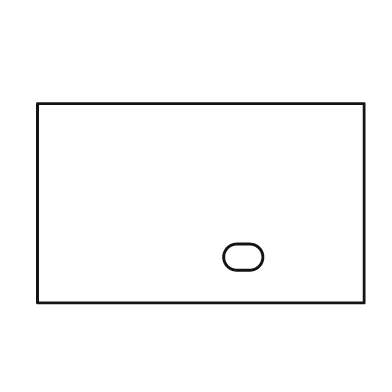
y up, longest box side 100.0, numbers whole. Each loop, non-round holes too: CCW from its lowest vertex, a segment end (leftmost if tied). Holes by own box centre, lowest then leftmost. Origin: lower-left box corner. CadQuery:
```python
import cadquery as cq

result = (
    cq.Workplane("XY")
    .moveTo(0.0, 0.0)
    .lineTo(100.0, 0.0)
    .lineTo(100.0, 61.0)
    .lineTo(0.0, 61.0)
    .close()
    .moveTo(61.0, 10.0)
    .lineTo(65.0, 10.0)
    .threePointArc((69.0, 14.0), (65.0, 18.0))
    .lineTo(61.0, 18.0)
    .threePointArc((57.0, 14.0), (61.0, 10.0))
    .close()
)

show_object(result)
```